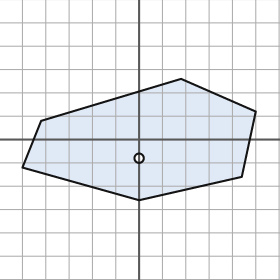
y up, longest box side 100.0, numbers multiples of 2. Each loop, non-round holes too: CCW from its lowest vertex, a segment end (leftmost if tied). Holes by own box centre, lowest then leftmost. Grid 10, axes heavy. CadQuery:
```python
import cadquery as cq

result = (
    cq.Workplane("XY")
    .moveTo(0.0, -26.0)
    .lineTo(44.0, -16.0)
    .lineTo(50.0, 12.0)
    .lineTo(18.0, 26.0)
    .lineTo(-42.0, 8.0)
    .lineTo(-50.0, -12.0)
    .close()
    .moveTo(0.0, -8.0)
    .circle(2.0)
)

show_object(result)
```